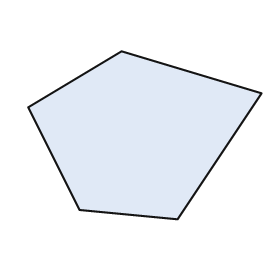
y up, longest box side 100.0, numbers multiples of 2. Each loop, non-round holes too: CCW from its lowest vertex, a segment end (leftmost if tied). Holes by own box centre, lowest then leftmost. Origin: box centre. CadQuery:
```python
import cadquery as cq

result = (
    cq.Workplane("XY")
    .moveTo(14.0, -36.0)
    .lineTo(50.0, 18.0)
    .lineTo(-10.0, 36.0)
    .lineTo(-50.0, 12.0)
    .lineTo(-28.0, -32.0)
    .close()
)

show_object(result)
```